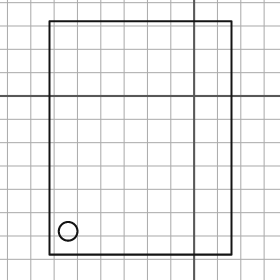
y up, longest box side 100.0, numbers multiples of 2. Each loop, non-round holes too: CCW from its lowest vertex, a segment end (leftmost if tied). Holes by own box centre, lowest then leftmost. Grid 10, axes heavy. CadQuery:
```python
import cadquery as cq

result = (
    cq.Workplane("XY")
    .moveTo(-62.0, -68.0)
    .lineTo(16.0, -68.0)
    .lineTo(16.0, 32.0)
    .lineTo(-62.0, 32.0)
    .close()
    .moveTo(-54.0, -58.0)
    .circle(4.0)
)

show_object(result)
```